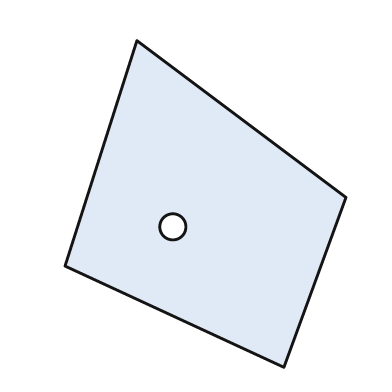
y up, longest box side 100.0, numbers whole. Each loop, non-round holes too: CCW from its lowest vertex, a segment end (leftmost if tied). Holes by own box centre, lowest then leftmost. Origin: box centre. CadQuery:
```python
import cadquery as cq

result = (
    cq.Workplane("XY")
    .moveTo(24.0, -50.0)
    .lineTo(43.0, 2.0)
    .lineTo(-21.0, 50.0)
    .lineTo(-43.0, -19.0)
    .close()
    .moveTo(-10.0, -7.0)
    .circle(4.0)
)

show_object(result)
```